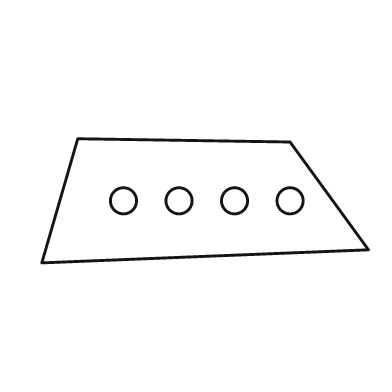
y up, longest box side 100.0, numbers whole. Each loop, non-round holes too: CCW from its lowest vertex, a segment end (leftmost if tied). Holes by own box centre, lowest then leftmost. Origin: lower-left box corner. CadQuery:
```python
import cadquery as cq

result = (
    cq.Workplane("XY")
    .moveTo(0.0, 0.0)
    .lineTo(100.0, 4.0)
    .lineTo(76.0, 37.0)
    .lineTo(11.0, 38.0)
    .close()
    .moveTo(25.0, 19.0)
    .circle(4.0)
    .moveTo(42.0, 19.0)
    .circle(4.0)
    .moveTo(59.0, 19.0)
    .circle(4.0)
    .moveTo(76.0, 19.0)
    .circle(4.0)
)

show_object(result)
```